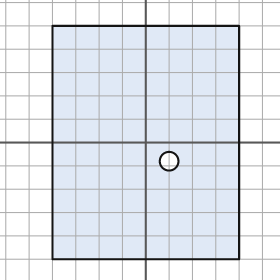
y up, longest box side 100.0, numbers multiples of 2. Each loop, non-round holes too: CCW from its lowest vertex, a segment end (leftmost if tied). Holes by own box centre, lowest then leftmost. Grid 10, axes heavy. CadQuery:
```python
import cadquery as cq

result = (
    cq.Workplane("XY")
    .moveTo(-40.0, -50.0)
    .lineTo(40.0, -50.0)
    .lineTo(40.0, 50.0)
    .lineTo(-40.0, 50.0)
    .close()
    .moveTo(10.0, -8.0)
    .circle(4.0)
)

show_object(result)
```